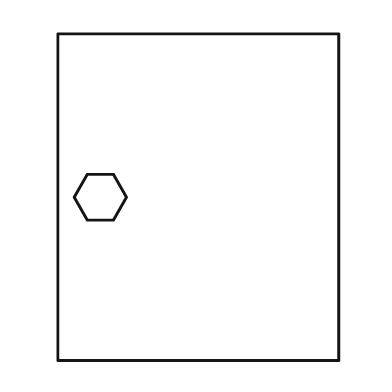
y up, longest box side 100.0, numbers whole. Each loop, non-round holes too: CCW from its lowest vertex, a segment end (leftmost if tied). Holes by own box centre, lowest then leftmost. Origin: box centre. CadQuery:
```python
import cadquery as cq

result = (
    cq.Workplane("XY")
    .moveTo(-43.0, -50.0)
    .lineTo(43.0, -50.0)
    .lineTo(43.0, 50.0)
    .lineTo(-43.0, 50.0)
    .close()
    .moveTo(-34.0, -7.0)
    .lineTo(-26.0, -7.0)
    .lineTo(-22.0, 0.0)
    .lineTo(-26.0, 7.0)
    .lineTo(-34.0, 7.0)
    .lineTo(-38.0, 0.0)
    .close()
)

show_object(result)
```